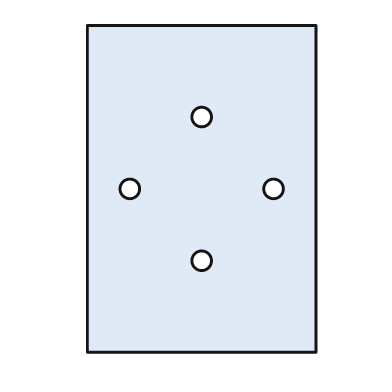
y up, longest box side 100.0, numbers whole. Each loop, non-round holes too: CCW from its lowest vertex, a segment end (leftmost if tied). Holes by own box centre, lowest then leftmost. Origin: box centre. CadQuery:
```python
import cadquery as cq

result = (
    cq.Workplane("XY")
    .moveTo(-35.0, -50.0)
    .lineTo(35.0, -50.0)
    .lineTo(35.0, 50.0)
    .lineTo(-35.0, 50.0)
    .close()
    .moveTo(0.0, -22.0)
    .circle(3.0)
    .moveTo(-22.0, 0.0)
    .circle(3.0)
    .moveTo(22.0, 0.0)
    .circle(3.0)
    .moveTo(0.0, 22.0)
    .circle(3.0)
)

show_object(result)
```